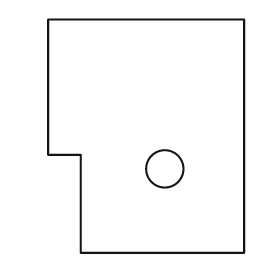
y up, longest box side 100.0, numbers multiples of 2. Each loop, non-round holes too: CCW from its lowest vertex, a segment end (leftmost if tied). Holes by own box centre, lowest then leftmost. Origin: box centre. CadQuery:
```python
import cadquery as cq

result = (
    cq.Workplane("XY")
    .moveTo(-28.0, -50.0)
    .lineTo(42.0, -50.0)
    .lineTo(42.0, 50.0)
    .lineTo(-42.0, 50.0)
    .lineTo(-42.0, -8.0)
    .lineTo(-28.0, -8.0)
    .close()
    .moveTo(8.0, -14.0)
    .circle(8.0)
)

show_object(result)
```